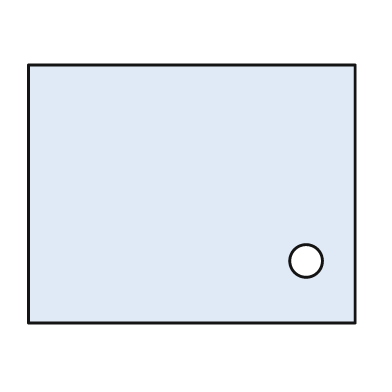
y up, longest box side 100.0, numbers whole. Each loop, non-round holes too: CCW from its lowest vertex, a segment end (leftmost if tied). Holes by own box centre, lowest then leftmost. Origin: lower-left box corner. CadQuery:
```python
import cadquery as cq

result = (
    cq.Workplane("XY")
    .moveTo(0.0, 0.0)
    .lineTo(100.0, 0.0)
    .lineTo(100.0, 79.0)
    .lineTo(0.0, 79.0)
    .close()
    .moveTo(85.0, 19.0)
    .circle(5.0)
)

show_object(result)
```